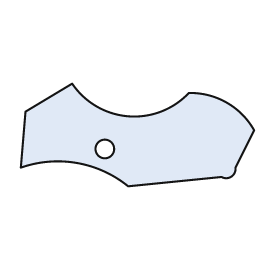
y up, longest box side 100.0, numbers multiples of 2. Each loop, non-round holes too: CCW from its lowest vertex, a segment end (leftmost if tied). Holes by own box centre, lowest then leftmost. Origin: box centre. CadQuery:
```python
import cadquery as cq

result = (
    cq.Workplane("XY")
    .moveTo(-4.0, -22.0)
    .lineTo(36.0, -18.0)
    .threePointArc((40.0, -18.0), (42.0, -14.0))
    .lineTo(50.0, 2.0)
    .threePointArc((38.0, 14.0), (22.0, 18.0))
    .threePointArc((-4.0, 8.0), (-28.0, 22.0))
    .lineTo(-48.0, 10.0)
    .lineTo(-50.0, -14.0)
    .threePointArc((-26.0, -12.0), (-4.0, -22.0))
    .close()
    .moveTo(-14.0, -6.0)
    .circle(4.0)
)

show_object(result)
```